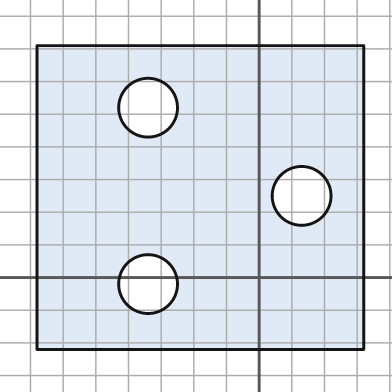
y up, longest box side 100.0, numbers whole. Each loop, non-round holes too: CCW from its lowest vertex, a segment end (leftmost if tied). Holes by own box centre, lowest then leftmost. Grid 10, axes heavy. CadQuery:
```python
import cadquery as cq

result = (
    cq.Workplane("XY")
    .moveTo(-68.0, -22.0)
    .lineTo(32.0, -22.0)
    .lineTo(32.0, 71.0)
    .lineTo(-68.0, 71.0)
    .close()
    .moveTo(-34.0, -2.0)
    .circle(9.0)
    .moveTo(13.0, 25.0)
    .circle(9.0)
    .moveTo(-34.0, 52.0)
    .circle(9.0)
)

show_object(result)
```